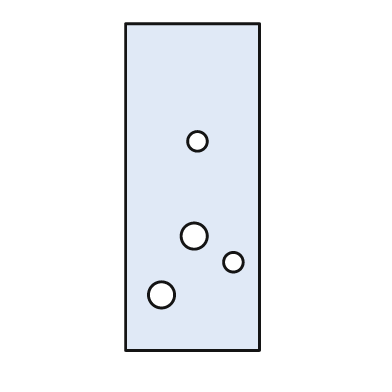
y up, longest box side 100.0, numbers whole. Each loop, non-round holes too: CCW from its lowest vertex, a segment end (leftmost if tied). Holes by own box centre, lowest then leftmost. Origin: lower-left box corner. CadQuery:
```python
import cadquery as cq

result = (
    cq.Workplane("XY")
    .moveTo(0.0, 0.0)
    .lineTo(41.0, 0.0)
    .lineTo(41.0, 100.0)
    .lineTo(0.0, 100.0)
    .close()
    .moveTo(11.0, 17.0)
    .circle(4.0)
    .moveTo(33.0, 27.0)
    .circle(3.0)
    .moveTo(21.0, 35.0)
    .circle(4.0)
    .moveTo(22.0, 64.0)
    .circle(3.0)
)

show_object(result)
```